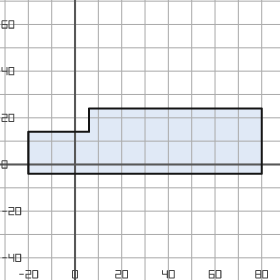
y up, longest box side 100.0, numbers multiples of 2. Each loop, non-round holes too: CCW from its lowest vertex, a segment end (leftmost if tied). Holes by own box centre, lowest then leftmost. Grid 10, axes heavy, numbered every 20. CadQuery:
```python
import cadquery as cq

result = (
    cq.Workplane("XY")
    .moveTo(-20.0, -4.0)
    .lineTo(80.0, -4.0)
    .lineTo(80.0, 24.0)
    .lineTo(6.0, 24.0)
    .lineTo(6.0, 14.0)
    .lineTo(-20.0, 14.0)
    .close()
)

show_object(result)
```